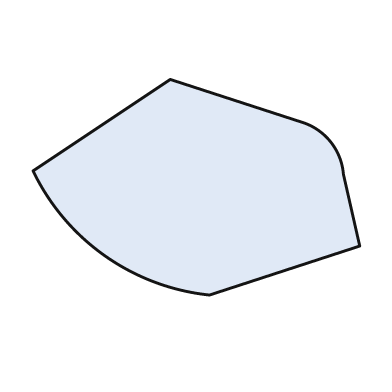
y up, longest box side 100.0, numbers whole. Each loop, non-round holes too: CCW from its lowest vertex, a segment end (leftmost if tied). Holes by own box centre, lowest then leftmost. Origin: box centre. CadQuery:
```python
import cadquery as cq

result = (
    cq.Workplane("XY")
    .moveTo(4.0, -33.0)
    .lineTo(50.0, -18.0)
    .lineTo(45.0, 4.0)
    .threePointArc((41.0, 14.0), (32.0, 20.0))
    .lineTo(-8.0, 33.0)
    .lineTo(-50.0, 5.0)
    .threePointArc((-28.0, -21.0), (4.0, -33.0))
    .close()
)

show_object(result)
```